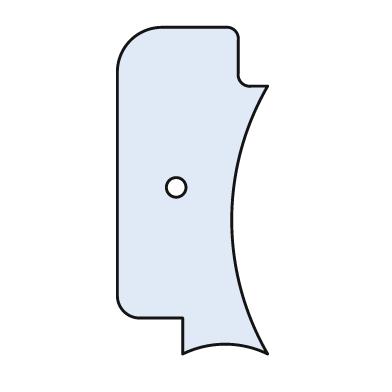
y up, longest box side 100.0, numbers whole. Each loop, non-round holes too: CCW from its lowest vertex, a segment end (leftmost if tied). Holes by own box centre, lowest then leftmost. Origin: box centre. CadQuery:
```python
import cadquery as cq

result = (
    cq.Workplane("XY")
    .moveTo(-3.0, -50.0)
    .threePointArc((10.0, -47.0), (23.0, -50.0))
    .threePointArc((12.0, -9.0), (23.0, 32.0))
    .lineTo(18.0, 32.0)
    .threePointArc((15.0, 33.0), (14.0, 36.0))
    .lineTo(14.0, 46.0)
    .threePointArc((13.0, 49.0), (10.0, 50.0))
    .lineTo(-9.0, 50.0)
    .threePointArc((-19.0, 46.0), (-23.0, 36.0))
    .lineTo(-23.0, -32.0)
    .threePointArc((-21.0, -37.0), (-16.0, -39.0))
    .lineTo(-3.0, -39.0)
    .close()
    .moveTo(-5.0, 1.0)
    .circle(3.0)
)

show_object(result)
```